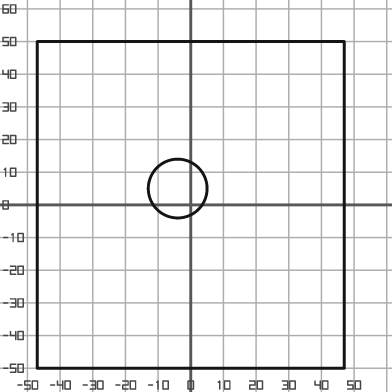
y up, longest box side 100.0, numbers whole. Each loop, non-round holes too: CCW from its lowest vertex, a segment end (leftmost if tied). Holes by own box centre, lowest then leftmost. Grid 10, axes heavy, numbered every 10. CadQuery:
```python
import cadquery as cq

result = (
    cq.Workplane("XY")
    .moveTo(-47.0, -50.0)
    .lineTo(47.0, -50.0)
    .lineTo(47.0, 50.0)
    .lineTo(-47.0, 50.0)
    .close()
    .moveTo(-4.0, 5.0)
    .circle(9.0)
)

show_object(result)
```